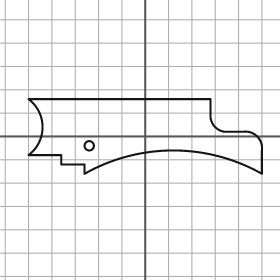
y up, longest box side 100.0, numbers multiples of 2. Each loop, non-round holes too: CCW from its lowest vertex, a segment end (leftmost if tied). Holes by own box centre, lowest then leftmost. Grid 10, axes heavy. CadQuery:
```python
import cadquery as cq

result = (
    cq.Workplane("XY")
    .moveTo(-26.0, -16.0)
    .threePointArc((12.0, -6.0), (50.0, -16.0))
    .lineTo(50.0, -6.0)
    .threePointArc((48.0, 0.0), (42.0, 2.0))
    .lineTo(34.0, 2.0)
    .threePointArc((30.0, 4.0), (28.0, 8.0))
    .lineTo(28.0, 16.0)
    .lineTo(-50.0, 16.0)
    .threePointArc((-44.0, 4.0), (-50.0, -8.0))
    .lineTo(-36.0, -8.0)
    .lineTo(-36.0, -12.0)
    .lineTo(-26.0, -12.0)
    .close()
    .moveTo(-24.0, -4.0)
    .circle(2.0)
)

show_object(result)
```